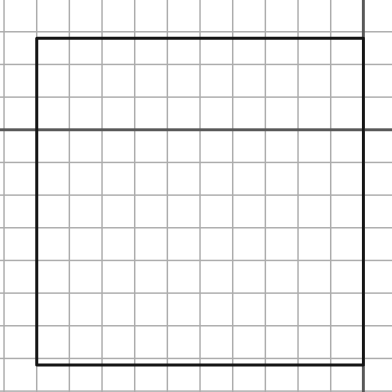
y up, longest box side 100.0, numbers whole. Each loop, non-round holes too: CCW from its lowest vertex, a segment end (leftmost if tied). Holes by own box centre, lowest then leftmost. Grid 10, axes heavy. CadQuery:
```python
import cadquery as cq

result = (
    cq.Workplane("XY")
    .moveTo(-100.0, -72.0)
    .lineTo(0.0, -72.0)
    .lineTo(0.0, 28.0)
    .lineTo(-100.0, 28.0)
    .close()
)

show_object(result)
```